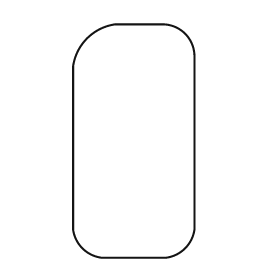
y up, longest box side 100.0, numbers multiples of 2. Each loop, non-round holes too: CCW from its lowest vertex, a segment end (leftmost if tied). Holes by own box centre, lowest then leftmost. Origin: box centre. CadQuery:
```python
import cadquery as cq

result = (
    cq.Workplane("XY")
    .moveTo(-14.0, -50.0)
    .lineTo(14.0, -50.0)
    .threePointArc((22.0, -46.0), (26.0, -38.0))
    .lineTo(26.0, 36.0)
    .threePointArc((22.0, 46.0), (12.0, 50.0))
    .lineTo(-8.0, 50.0)
    .threePointArc((-20.0, 44.0), (-26.0, 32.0))
    .lineTo(-26.0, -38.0)
    .threePointArc((-22.0, -46.0), (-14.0, -50.0))
    .close()
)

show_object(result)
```